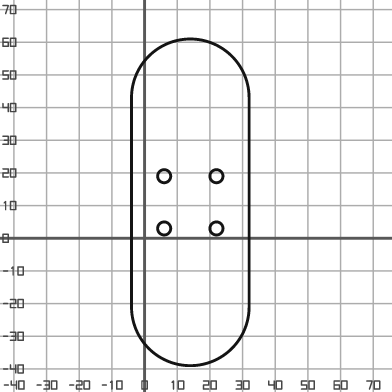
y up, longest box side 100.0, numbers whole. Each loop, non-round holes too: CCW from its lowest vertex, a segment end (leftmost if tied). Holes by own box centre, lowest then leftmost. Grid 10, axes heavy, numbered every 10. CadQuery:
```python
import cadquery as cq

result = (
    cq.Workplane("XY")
    .moveTo(-4.0, -21.0)
    .threePointArc((14.0, -39.0), (32.0, -21.0))
    .lineTo(32.0, 43.0)
    .threePointArc((14.0, 61.0), (-4.0, 43.0))
    .close()
    .moveTo(6.0, 3.0)
    .circle(2.0)
    .moveTo(22.0, 3.0)
    .circle(2.0)
    .moveTo(6.0, 19.0)
    .circle(2.0)
    .moveTo(22.0, 19.0)
    .circle(2.0)
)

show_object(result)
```